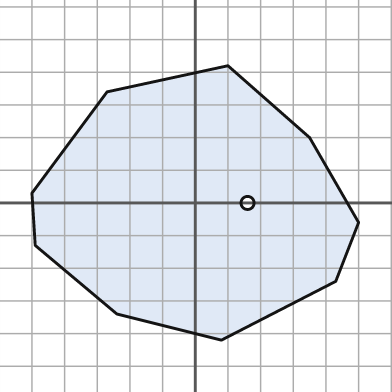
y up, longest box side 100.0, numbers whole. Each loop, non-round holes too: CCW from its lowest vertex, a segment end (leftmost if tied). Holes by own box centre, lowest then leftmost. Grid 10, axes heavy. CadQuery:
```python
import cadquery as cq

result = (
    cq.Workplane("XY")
    .moveTo(8.0, -42.0)
    .lineTo(43.0, -24.0)
    .lineTo(50.0, -6.0)
    .lineTo(35.0, 20.0)
    .lineTo(10.0, 42.0)
    .lineTo(-27.0, 34.0)
    .lineTo(-50.0, 3.0)
    .lineTo(-49.0, -13.0)
    .lineTo(-24.0, -34.0)
    .close()
    .moveTo(16.0, 0.0)
    .circle(2.0)
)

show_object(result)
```